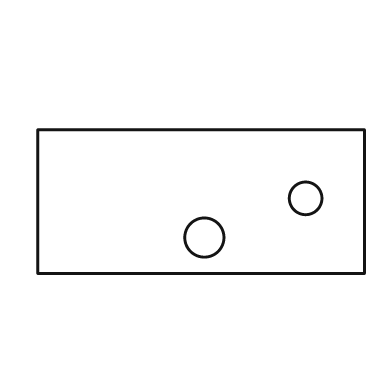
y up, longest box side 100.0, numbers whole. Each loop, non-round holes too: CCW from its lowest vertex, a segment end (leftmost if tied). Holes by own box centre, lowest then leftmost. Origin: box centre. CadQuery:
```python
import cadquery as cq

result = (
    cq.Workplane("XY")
    .moveTo(-50.0, -22.0)
    .lineTo(50.0, -22.0)
    .lineTo(50.0, 22.0)
    .lineTo(-50.0, 22.0)
    .close()
    .moveTo(1.0, -11.0)
    .circle(6.0)
    .moveTo(32.0, 1.0)
    .circle(5.0)
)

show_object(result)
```